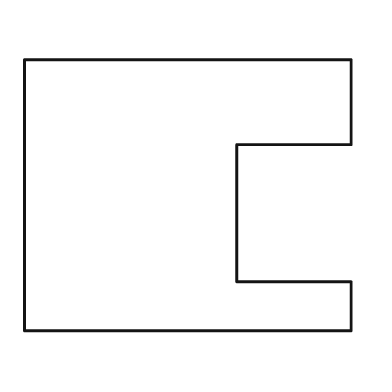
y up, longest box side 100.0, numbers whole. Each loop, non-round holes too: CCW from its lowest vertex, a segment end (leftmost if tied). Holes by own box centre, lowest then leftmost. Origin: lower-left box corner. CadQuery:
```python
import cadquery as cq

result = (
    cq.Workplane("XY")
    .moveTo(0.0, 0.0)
    .lineTo(100.0, 0.0)
    .lineTo(100.0, 15.0)
    .lineTo(65.0, 15.0)
    .lineTo(65.0, 57.0)
    .lineTo(100.0, 57.0)
    .lineTo(100.0, 83.0)
    .lineTo(0.0, 83.0)
    .close()
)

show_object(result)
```